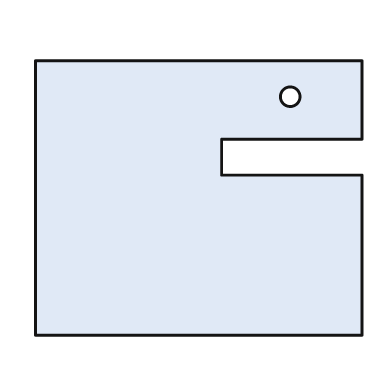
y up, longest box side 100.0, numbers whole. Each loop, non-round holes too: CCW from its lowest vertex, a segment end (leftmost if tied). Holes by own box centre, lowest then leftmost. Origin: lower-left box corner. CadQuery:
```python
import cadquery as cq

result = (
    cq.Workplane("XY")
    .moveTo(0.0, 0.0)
    .lineTo(100.0, 0.0)
    .lineTo(100.0, 49.0)
    .lineTo(57.0, 49.0)
    .lineTo(57.0, 60.0)
    .lineTo(100.0, 60.0)
    .lineTo(100.0, 84.0)
    .lineTo(0.0, 84.0)
    .close()
    .moveTo(78.0, 73.0)
    .circle(3.0)
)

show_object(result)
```